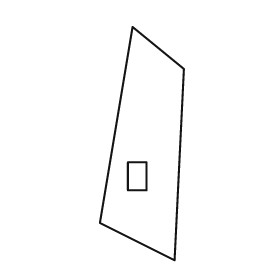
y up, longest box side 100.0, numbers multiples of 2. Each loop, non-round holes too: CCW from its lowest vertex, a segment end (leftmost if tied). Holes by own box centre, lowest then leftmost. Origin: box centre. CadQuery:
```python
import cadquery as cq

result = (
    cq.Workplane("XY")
    .moveTo(14.0, -50.0)
    .lineTo(18.0, 32.0)
    .lineTo(-4.0, 50.0)
    .lineTo(-18.0, -34.0)
    .close()
    .moveTo(-6.0, -20.0)
    .lineTo(2.0, -20.0)
    .lineTo(2.0, -8.0)
    .lineTo(-6.0, -8.0)
    .close()
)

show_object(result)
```